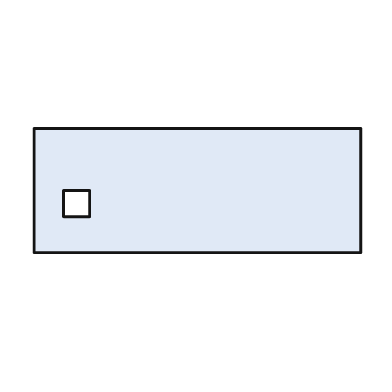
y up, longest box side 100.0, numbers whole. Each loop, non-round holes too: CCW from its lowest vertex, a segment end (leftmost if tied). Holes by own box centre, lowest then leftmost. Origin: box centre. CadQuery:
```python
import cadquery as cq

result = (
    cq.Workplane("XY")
    .moveTo(-50.0, -19.0)
    .lineTo(50.0, -19.0)
    .lineTo(50.0, 19.0)
    .lineTo(-50.0, 19.0)
    .close()
    .moveTo(-41.0, -8.0)
    .lineTo(-33.0, -8.0)
    .lineTo(-33.0, 0.0)
    .lineTo(-41.0, 0.0)
    .close()
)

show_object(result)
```